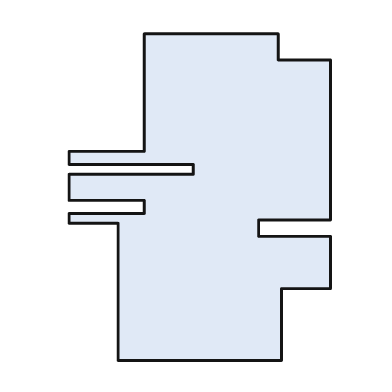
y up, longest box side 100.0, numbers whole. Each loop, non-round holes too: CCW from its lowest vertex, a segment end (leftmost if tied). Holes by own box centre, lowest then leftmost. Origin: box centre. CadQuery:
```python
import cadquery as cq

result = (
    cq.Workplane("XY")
    .moveTo(-25.0, -50.0)
    .lineTo(25.0, -50.0)
    .lineTo(25.0, -28.0)
    .lineTo(40.0, -28.0)
    .lineTo(40.0, -12.0)
    .lineTo(18.0, -12.0)
    .lineTo(18.0, -7.0)
    .lineTo(40.0, -7.0)
    .lineTo(40.0, 42.0)
    .lineTo(24.0, 42.0)
    .lineTo(24.0, 50.0)
    .lineTo(-17.0, 50.0)
    .lineTo(-17.0, 14.0)
    .lineTo(-40.0, 14.0)
    .lineTo(-40.0, 10.0)
    .lineTo(-2.0, 10.0)
    .lineTo(-2.0, 7.0)
    .lineTo(-40.0, 7.0)
    .lineTo(-40.0, -1.0)
    .lineTo(-17.0, -1.0)
    .lineTo(-17.0, -5.0)
    .lineTo(-40.0, -5.0)
    .lineTo(-40.0, -8.0)
    .lineTo(-25.0, -8.0)
    .close()
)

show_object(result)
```